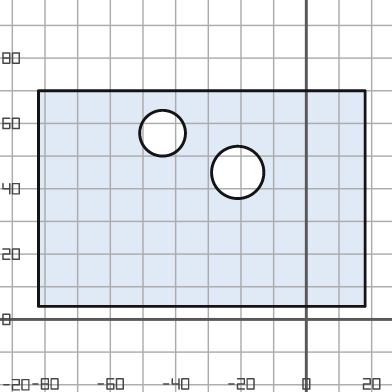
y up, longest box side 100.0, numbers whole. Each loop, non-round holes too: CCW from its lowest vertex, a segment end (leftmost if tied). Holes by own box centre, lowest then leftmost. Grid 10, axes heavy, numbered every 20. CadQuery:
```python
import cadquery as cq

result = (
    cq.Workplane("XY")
    .moveTo(-82.0, 4.0)
    .lineTo(18.0, 4.0)
    .lineTo(18.0, 70.0)
    .lineTo(-82.0, 70.0)
    .close()
    .moveTo(-21.0, 45.0)
    .circle(8.0)
    .moveTo(-44.0, 57.0)
    .circle(7.0)
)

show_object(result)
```